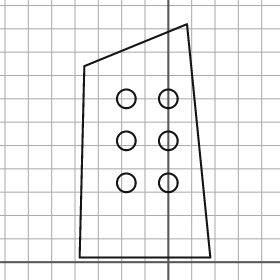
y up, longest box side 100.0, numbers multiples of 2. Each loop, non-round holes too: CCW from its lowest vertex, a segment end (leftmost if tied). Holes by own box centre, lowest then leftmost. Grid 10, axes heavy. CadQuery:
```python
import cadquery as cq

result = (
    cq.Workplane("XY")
    .moveTo(-38.0, 2.0)
    .lineTo(18.0, 2.0)
    .lineTo(8.0, 102.0)
    .lineTo(-36.0, 84.0)
    .close()
    .moveTo(-18.0, 34.0)
    .circle(4.0)
    .moveTo(0.0, 34.0)
    .circle(4.0)
    .moveTo(-18.0, 52.0)
    .circle(4.0)
    .moveTo(0.0, 52.0)
    .circle(4.0)
    .moveTo(-18.0, 70.0)
    .circle(4.0)
    .moveTo(0.0, 70.0)
    .circle(4.0)
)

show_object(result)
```